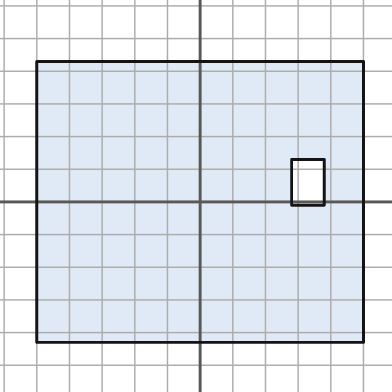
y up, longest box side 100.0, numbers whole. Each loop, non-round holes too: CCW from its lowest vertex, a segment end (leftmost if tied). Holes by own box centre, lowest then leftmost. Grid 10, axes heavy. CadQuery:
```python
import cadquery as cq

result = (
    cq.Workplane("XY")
    .moveTo(-50.0, -43.0)
    .lineTo(50.0, -43.0)
    .lineTo(50.0, 43.0)
    .lineTo(-50.0, 43.0)
    .close()
    .moveTo(28.0, -1.0)
    .lineTo(38.0, -1.0)
    .lineTo(38.0, 13.0)
    .lineTo(28.0, 13.0)
    .close()
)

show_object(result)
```